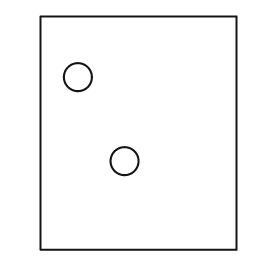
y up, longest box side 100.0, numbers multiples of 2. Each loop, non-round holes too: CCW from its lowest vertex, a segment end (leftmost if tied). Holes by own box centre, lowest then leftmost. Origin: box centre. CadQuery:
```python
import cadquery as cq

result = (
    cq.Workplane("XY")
    .moveTo(-42.0, -50.0)
    .lineTo(42.0, -50.0)
    .lineTo(42.0, 50.0)
    .lineTo(-42.0, 50.0)
    .close()
    .moveTo(-6.0, -12.0)
    .circle(6.0)
    .moveTo(-26.0, 24.0)
    .circle(6.0)
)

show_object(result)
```